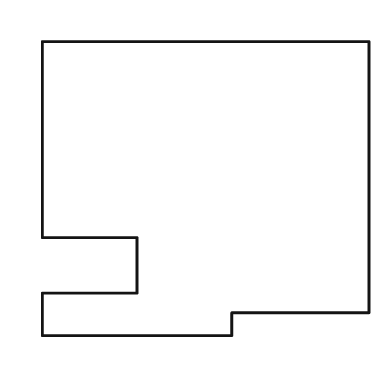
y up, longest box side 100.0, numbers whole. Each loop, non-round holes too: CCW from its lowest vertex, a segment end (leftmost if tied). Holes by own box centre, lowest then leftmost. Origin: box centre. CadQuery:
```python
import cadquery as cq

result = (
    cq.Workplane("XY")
    .moveTo(-50.0, -45.0)
    .lineTo(8.0, -45.0)
    .lineTo(8.0, -38.0)
    .lineTo(50.0, -38.0)
    .lineTo(50.0, 45.0)
    .lineTo(-50.0, 45.0)
    .lineTo(-50.0, -15.0)
    .lineTo(-21.0, -15.0)
    .lineTo(-21.0, -32.0)
    .lineTo(-50.0, -32.0)
    .close()
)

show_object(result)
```